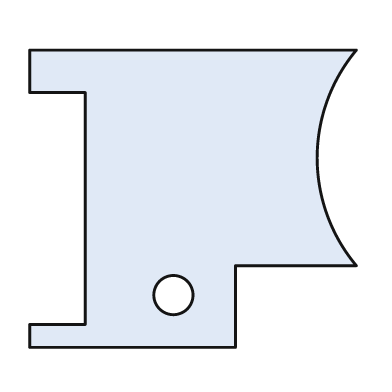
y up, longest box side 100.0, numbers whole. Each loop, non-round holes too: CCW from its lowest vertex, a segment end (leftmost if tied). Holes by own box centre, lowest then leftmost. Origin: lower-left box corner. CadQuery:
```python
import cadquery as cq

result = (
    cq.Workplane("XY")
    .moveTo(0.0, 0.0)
    .lineTo(63.0, 0.0)
    .lineTo(63.0, 25.0)
    .lineTo(100.0, 25.0)
    .threePointArc((88.0, 58.0), (100.0, 91.0))
    .lineTo(0.0, 91.0)
    .lineTo(0.0, 78.0)
    .lineTo(17.0, 78.0)
    .lineTo(17.0, 7.0)
    .lineTo(0.0, 7.0)
    .close()
    .moveTo(44.0, 16.0)
    .circle(6.0)
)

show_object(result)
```